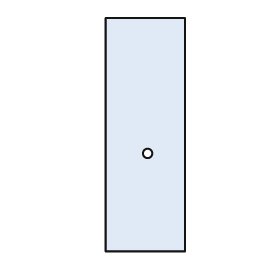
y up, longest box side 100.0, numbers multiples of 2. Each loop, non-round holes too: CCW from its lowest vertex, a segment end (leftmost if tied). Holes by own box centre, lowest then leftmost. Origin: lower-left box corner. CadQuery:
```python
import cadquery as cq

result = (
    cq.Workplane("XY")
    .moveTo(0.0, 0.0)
    .lineTo(34.0, 0.0)
    .lineTo(34.0, 100.0)
    .lineTo(0.0, 100.0)
    .close()
    .moveTo(18.0, 42.0)
    .circle(2.0)
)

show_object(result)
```